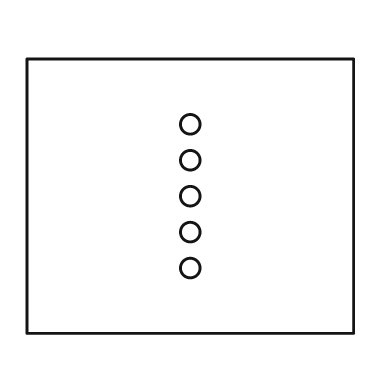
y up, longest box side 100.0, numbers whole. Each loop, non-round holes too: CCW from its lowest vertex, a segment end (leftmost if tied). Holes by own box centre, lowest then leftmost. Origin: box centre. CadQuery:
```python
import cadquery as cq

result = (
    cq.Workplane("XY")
    .moveTo(-50.0, -42.0)
    .lineTo(50.0, -42.0)
    .lineTo(50.0, 42.0)
    .lineTo(-50.0, 42.0)
    .close()
    .moveTo(0.0, -22.0)
    .circle(3.0)
    .moveTo(0.0, -11.0)
    .circle(3.0)
    .moveTo(0.0, 0.0)
    .circle(3.0)
    .moveTo(0.0, 11.0)
    .circle(3.0)
    .moveTo(0.0, 22.0)
    .circle(3.0)
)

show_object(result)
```